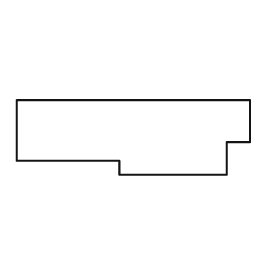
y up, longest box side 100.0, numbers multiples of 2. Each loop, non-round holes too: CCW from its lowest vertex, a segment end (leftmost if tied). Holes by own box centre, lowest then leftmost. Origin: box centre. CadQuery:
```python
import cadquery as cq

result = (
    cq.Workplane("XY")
    .moveTo(-6.0, -16.0)
    .lineTo(40.0, -16.0)
    .lineTo(40.0, -2.0)
    .lineTo(50.0, -2.0)
    .lineTo(50.0, 16.0)
    .lineTo(-50.0, 16.0)
    .lineTo(-50.0, -10.0)
    .lineTo(-6.0, -10.0)
    .close()
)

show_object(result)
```